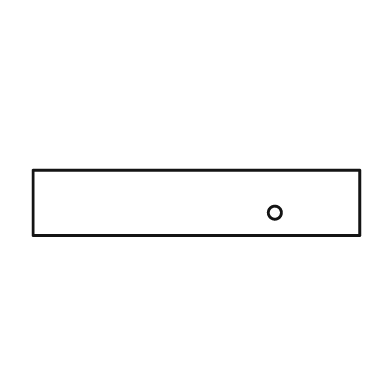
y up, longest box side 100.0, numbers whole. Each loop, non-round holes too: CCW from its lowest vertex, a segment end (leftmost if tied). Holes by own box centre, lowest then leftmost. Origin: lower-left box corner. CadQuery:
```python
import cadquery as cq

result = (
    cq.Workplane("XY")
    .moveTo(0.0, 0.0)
    .lineTo(100.0, 0.0)
    .lineTo(100.0, 20.0)
    .lineTo(0.0, 20.0)
    .close()
    .moveTo(74.0, 7.0)
    .circle(2.0)
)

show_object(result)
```